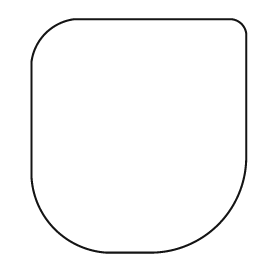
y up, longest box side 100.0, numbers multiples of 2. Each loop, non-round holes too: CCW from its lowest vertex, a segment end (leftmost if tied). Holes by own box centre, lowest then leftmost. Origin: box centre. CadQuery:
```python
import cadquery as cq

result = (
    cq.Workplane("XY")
    .moveTo(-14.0, -50.0)
    .lineTo(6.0, -50.0)
    .threePointArc((34.0, -38.0), (46.0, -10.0))
    .lineTo(46.0, 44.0)
    .threePointArc((44.0, 48.0), (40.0, 50.0))
    .lineTo(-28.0, 50.0)
    .threePointArc((-40.0, 44.0), (-46.0, 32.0))
    .lineTo(-46.0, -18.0)
    .threePointArc((-36.0, -40.0), (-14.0, -50.0))
    .close()
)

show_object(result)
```